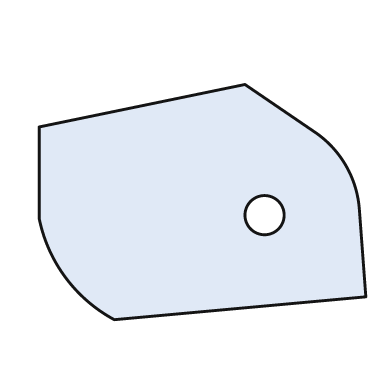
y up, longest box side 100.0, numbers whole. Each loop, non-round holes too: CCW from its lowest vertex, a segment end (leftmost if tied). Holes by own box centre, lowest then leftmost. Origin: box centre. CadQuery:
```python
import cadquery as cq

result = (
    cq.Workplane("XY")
    .moveTo(-27.0, -36.0)
    .lineTo(50.0, -29.0)
    .lineTo(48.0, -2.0)
    .threePointArc((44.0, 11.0), (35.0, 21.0))
    .lineTo(13.0, 36.0)
    .lineTo(-50.0, 23.0)
    .lineTo(-50.0, -5.0)
    .threePointArc((-42.0, -23.0), (-27.0, -36.0))
    .close()
    .moveTo(19.0, -4.0)
    .circle(6.0)
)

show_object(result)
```